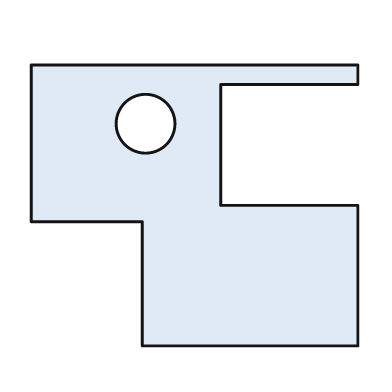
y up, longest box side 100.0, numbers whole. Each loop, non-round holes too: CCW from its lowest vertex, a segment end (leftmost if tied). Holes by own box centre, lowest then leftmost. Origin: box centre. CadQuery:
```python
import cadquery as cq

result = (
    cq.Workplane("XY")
    .moveTo(-16.0, -43.0)
    .lineTo(50.0, -43.0)
    .lineTo(50.0, 0.0)
    .lineTo(8.0, 0.0)
    .lineTo(8.0, 37.0)
    .lineTo(50.0, 37.0)
    .lineTo(50.0, 43.0)
    .lineTo(-50.0, 43.0)
    .lineTo(-50.0, -5.0)
    .lineTo(-16.0, -5.0)
    .close()
    .moveTo(-15.0, 25.0)
    .circle(9.0)
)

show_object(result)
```